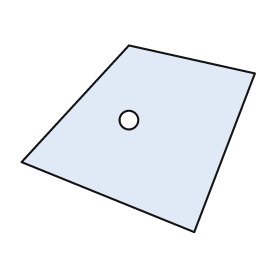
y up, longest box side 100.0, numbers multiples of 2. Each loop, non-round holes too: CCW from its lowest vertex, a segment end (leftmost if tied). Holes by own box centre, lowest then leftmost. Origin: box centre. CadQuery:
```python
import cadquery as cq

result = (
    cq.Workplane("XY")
    .moveTo(24.0, -40.0)
    .lineTo(50.0, 28.0)
    .lineTo(-4.0, 40.0)
    .lineTo(-50.0, -10.0)
    .close()
    .moveTo(-4.0, 8.0)
    .circle(4.0)
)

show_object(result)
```